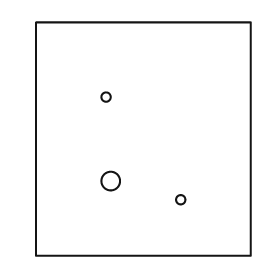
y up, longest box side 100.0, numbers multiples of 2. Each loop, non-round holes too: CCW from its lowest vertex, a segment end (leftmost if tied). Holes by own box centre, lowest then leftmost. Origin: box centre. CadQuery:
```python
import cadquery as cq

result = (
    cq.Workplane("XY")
    .moveTo(-46.0, -50.0)
    .lineTo(46.0, -50.0)
    .lineTo(46.0, 50.0)
    .lineTo(-46.0, 50.0)
    .close()
    .moveTo(16.0, -26.0)
    .circle(2.0)
    .moveTo(-14.0, -18.0)
    .circle(4.0)
    .moveTo(-16.0, 18.0)
    .circle(2.0)
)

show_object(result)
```